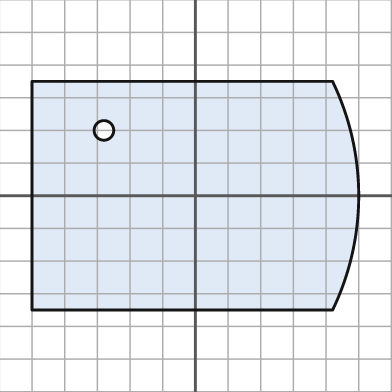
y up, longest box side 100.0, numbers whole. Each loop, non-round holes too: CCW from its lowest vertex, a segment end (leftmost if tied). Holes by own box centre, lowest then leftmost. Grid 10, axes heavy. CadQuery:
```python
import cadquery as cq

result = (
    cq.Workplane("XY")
    .moveTo(-50.0, -35.0)
    .lineTo(42.0, -35.0)
    .threePointArc((50.0, 0.0), (42.0, 35.0))
    .lineTo(-50.0, 35.0)
    .close()
    .moveTo(-28.0, 20.0)
    .circle(3.0)
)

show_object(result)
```